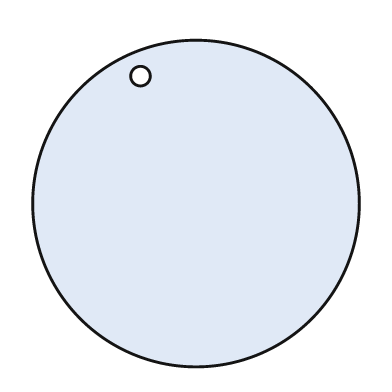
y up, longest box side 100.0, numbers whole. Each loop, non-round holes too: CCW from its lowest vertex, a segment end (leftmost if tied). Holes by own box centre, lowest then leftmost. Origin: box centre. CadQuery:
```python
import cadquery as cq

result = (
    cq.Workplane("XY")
    .moveTo(0.0, 0.0)
    .circle(50.0)
    .moveTo(-17.0, 39.0)
    .circle(3.0)
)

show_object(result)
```